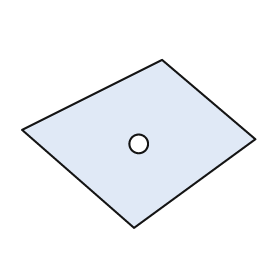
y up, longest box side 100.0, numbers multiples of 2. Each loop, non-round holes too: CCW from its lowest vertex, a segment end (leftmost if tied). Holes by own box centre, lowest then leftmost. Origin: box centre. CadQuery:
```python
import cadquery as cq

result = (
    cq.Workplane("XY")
    .moveTo(-2.0, -36.0)
    .lineTo(50.0, 2.0)
    .lineTo(10.0, 36.0)
    .lineTo(-50.0, 6.0)
    .close()
    .moveTo(0.0, 0.0)
    .circle(4.0)
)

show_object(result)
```